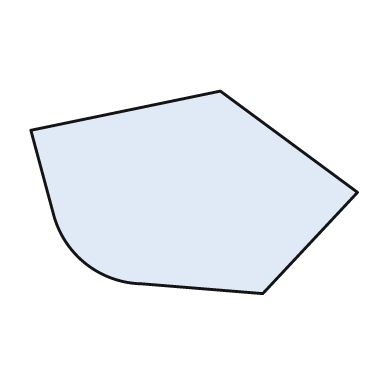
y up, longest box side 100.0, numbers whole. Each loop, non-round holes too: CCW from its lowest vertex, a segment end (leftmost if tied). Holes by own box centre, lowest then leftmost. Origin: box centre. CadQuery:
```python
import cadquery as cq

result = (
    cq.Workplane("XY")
    .moveTo(21.0, -31.0)
    .lineTo(50.0, 0.0)
    .lineTo(8.0, 31.0)
    .lineTo(-50.0, 19.0)
    .lineTo(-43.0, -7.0)
    .threePointArc((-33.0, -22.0), (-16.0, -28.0))
    .close()
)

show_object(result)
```